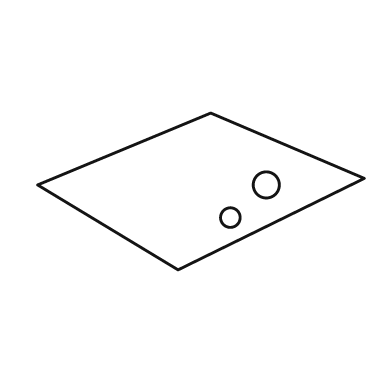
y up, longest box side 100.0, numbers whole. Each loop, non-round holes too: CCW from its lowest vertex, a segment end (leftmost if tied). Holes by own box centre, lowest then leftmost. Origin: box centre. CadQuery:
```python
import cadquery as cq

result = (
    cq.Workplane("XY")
    .moveTo(-7.0, -24.0)
    .lineTo(50.0, 4.0)
    .lineTo(3.0, 24.0)
    .lineTo(-50.0, 2.0)
    .close()
    .moveTo(9.0, -8.0)
    .circle(3.0)
    .moveTo(20.0, 2.0)
    .circle(4.0)
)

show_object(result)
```